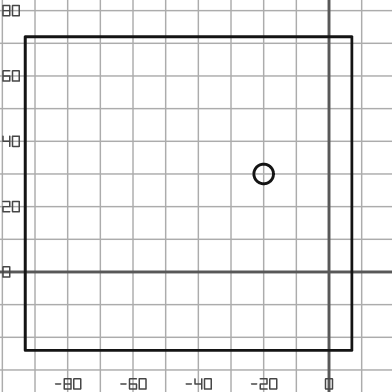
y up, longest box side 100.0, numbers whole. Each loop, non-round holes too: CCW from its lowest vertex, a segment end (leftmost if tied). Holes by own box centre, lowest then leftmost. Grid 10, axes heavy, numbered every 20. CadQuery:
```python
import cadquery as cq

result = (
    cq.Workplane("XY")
    .moveTo(-93.0, -24.0)
    .lineTo(7.0, -24.0)
    .lineTo(7.0, 72.0)
    .lineTo(-93.0, 72.0)
    .close()
    .moveTo(-20.0, 30.0)
    .circle(3.0)
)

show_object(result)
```